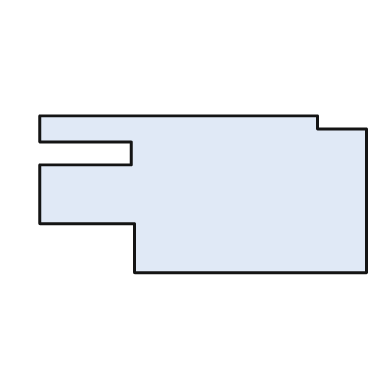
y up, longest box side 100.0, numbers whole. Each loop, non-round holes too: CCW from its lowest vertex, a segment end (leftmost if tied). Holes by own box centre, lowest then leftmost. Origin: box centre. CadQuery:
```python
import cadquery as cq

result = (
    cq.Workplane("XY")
    .moveTo(-21.0, -24.0)
    .lineTo(50.0, -24.0)
    .lineTo(50.0, 20.0)
    .lineTo(35.0, 20.0)
    .lineTo(35.0, 24.0)
    .lineTo(-50.0, 24.0)
    .lineTo(-50.0, 16.0)
    .lineTo(-22.0, 16.0)
    .lineTo(-22.0, 9.0)
    .lineTo(-50.0, 9.0)
    .lineTo(-50.0, -9.0)
    .lineTo(-21.0, -9.0)
    .close()
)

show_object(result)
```